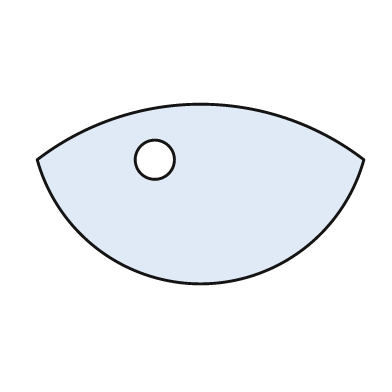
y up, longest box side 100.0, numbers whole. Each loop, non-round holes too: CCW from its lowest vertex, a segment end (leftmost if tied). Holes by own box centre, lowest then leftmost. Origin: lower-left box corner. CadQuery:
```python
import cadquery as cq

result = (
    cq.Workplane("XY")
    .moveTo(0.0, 38.0)
    .threePointArc((50.0, 0.0), (100.0, 38.0))
    .threePointArc((50.0, 55.0), (0.0, 38.0))
    .close()
    .moveTo(36.0, 38.0)
    .circle(6.0)
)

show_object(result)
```